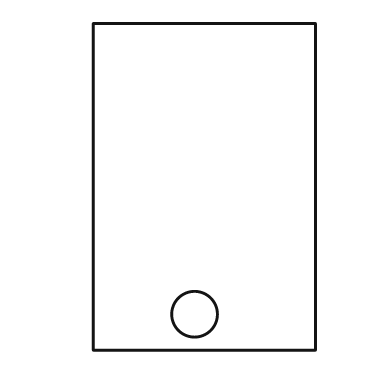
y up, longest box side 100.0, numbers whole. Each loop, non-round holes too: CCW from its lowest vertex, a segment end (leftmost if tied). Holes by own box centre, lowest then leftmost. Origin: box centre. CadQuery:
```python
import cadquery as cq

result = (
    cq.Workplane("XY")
    .moveTo(-34.0, -50.0)
    .lineTo(34.0, -50.0)
    .lineTo(34.0, 50.0)
    .lineTo(-34.0, 50.0)
    .close()
    .moveTo(-3.0, -39.0)
    .circle(7.0)
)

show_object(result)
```